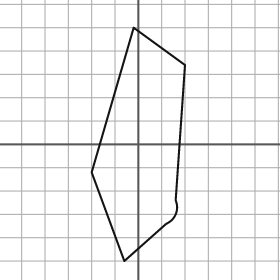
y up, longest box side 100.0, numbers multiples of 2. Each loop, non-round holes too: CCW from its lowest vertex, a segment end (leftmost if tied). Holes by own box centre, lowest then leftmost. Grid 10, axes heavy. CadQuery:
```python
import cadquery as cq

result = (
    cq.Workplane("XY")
    .moveTo(-6.0, -50.0)
    .lineTo(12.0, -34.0)
    .threePointArc((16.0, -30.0), (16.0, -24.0))
    .lineTo(20.0, 34.0)
    .lineTo(-2.0, 50.0)
    .lineTo(-20.0, -12.0)
    .close()
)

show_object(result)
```